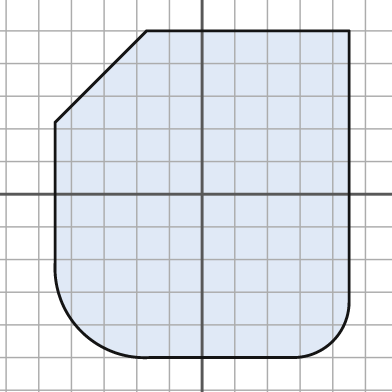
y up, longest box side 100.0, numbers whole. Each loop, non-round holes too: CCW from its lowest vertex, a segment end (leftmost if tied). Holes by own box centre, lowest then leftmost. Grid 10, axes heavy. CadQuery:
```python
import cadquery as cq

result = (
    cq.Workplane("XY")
    .moveTo(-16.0, -50.0)
    .lineTo(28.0, -50.0)
    .threePointArc((40.0, -45.0), (45.0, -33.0))
    .lineTo(45.0, 50.0)
    .lineTo(-17.0, 50.0)
    .lineTo(-45.0, 22.0)
    .lineTo(-45.0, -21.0)
    .threePointArc((-37.0, -42.0), (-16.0, -50.0))
    .close()
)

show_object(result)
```